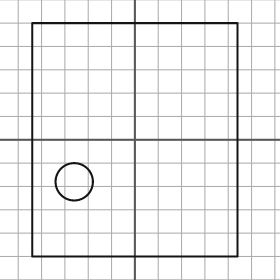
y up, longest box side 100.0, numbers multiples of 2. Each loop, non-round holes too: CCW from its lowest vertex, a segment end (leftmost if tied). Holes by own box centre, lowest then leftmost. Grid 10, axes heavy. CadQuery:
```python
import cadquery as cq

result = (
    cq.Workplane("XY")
    .moveTo(-44.0, -50.0)
    .lineTo(44.0, -50.0)
    .lineTo(44.0, 50.0)
    .lineTo(-44.0, 50.0)
    .close()
    .moveTo(-26.0, -18.0)
    .circle(8.0)
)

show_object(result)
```